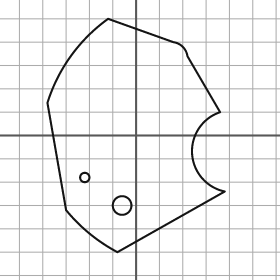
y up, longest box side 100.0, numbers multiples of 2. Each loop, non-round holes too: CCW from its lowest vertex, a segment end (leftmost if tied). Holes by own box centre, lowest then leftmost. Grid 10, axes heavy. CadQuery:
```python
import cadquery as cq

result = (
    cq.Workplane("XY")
    .moveTo(-8.0, -50.0)
    .lineTo(38.0, -24.0)
    .threePointArc((24.0, -8.0), (36.0, 10.0))
    .lineTo(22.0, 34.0)
    .threePointArc((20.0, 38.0), (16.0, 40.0))
    .lineTo(-12.0, 50.0)
    .threePointArc((-28.0, 34.0), (-38.0, 14.0))
    .lineTo(-30.0, -32.0)
    .threePointArc((-20.0, -42.0), (-8.0, -50.0))
    .close()
    .moveTo(-6.0, -30.0)
    .circle(4.0)
    .moveTo(-22.0, -18.0)
    .circle(2.0)
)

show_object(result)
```